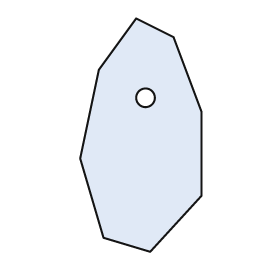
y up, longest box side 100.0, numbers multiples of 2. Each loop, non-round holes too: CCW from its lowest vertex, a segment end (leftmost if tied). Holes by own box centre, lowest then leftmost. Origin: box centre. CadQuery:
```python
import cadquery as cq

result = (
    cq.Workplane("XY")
    .moveTo(4.0, -50.0)
    .lineTo(26.0, -26.0)
    .lineTo(26.0, 10.0)
    .lineTo(14.0, 42.0)
    .lineTo(-2.0, 50.0)
    .lineTo(-18.0, 28.0)
    .lineTo(-26.0, -10.0)
    .lineTo(-16.0, -44.0)
    .close()
    .moveTo(2.0, 16.0)
    .circle(4.0)
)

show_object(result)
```